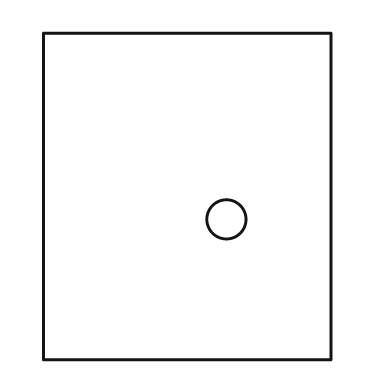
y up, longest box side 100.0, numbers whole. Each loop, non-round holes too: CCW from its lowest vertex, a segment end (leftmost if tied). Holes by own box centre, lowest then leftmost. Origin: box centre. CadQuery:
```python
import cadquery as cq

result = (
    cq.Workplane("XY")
    .moveTo(-44.0, -50.0)
    .lineTo(44.0, -50.0)
    .lineTo(44.0, 50.0)
    .lineTo(-44.0, 50.0)
    .close()
    .moveTo(12.0, -7.0)
    .circle(6.0)
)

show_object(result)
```